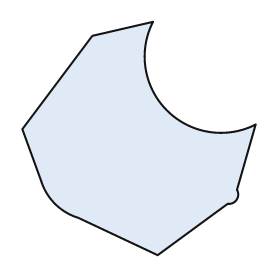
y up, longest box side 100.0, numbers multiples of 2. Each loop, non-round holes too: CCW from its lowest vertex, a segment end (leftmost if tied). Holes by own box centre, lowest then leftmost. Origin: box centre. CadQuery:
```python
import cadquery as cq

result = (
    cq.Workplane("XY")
    .moveTo(8.0, -50.0)
    .lineTo(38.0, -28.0)
    .threePointArc((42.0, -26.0), (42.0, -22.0))
    .lineTo(50.0, 6.0)
    .threePointArc((12.0, 12.0), (6.0, 50.0))
    .lineTo(-20.0, 44.0)
    .lineTo(-50.0, 4.0)
    .lineTo(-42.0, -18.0)
    .threePointArc((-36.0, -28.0), (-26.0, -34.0))
    .close()
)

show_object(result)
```